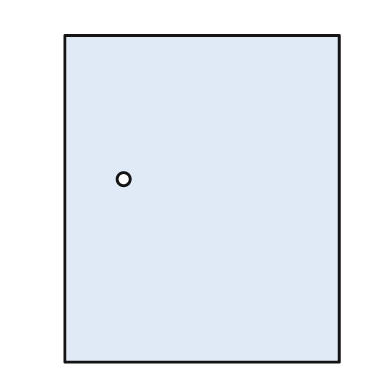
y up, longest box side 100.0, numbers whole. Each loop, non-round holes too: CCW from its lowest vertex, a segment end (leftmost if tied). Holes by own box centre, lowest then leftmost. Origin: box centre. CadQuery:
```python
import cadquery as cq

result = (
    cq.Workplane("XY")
    .moveTo(-42.0, -50.0)
    .lineTo(42.0, -50.0)
    .lineTo(42.0, 50.0)
    .lineTo(-42.0, 50.0)
    .close()
    .moveTo(-24.0, 6.0)
    .circle(2.0)
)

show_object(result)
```